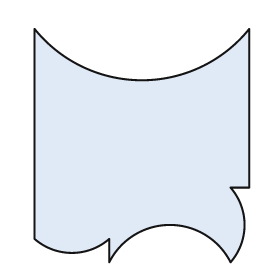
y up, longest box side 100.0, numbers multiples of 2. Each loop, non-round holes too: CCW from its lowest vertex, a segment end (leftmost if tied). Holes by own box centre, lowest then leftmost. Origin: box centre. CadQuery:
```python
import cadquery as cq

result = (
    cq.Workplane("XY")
    .moveTo(-14.0, -50.0)
    .threePointArc((12.0, -34.0), (38.0, -50.0))
    .threePointArc((44.0, -34.0), (38.0, -18.0))
    .lineTo(46.0, -18.0)
    .lineTo(46.0, 50.0)
    .threePointArc((0.0, 28.0), (-46.0, 50.0))
    .lineTo(-46.0, -40.0)
    .threePointArc((-30.0, -46.0), (-14.0, -40.0))
    .close()
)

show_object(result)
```